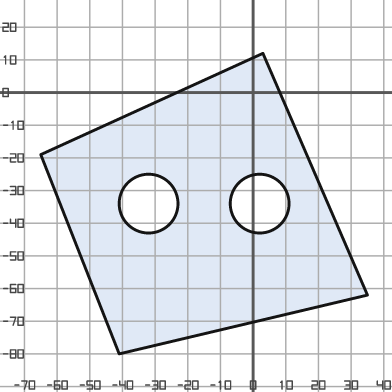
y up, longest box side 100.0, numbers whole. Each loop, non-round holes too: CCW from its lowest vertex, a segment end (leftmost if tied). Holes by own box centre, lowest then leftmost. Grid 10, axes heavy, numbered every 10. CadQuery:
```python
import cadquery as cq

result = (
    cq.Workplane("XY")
    .moveTo(-41.0, -80.0)
    .lineTo(35.0, -62.0)
    .lineTo(3.0, 12.0)
    .lineTo(-65.0, -19.0)
    .close()
    .moveTo(-32.0, -34.0)
    .circle(9.0)
    .moveTo(2.0, -34.0)
    .circle(9.0)
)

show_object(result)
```